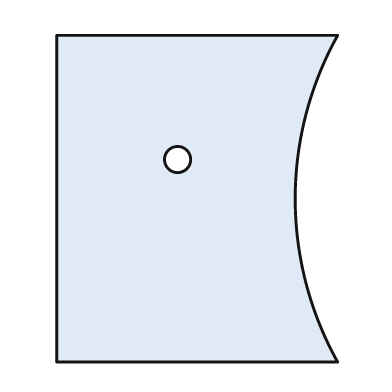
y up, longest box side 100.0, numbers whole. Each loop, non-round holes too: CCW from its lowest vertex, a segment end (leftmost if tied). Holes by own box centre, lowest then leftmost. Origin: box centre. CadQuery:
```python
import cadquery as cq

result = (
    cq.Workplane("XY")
    .moveTo(-43.0, -50.0)
    .lineTo(43.0, -50.0)
    .threePointArc((30.0, 0.0), (43.0, 50.0))
    .lineTo(-43.0, 50.0)
    .close()
    .moveTo(-6.0, 12.0)
    .circle(4.0)
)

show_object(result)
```